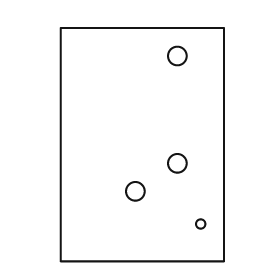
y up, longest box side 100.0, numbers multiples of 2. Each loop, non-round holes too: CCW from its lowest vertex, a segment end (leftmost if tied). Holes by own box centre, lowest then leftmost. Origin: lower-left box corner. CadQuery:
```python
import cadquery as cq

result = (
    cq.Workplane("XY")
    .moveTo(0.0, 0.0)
    .lineTo(70.0, 0.0)
    .lineTo(70.0, 100.0)
    .lineTo(0.0, 100.0)
    .close()
    .moveTo(60.0, 16.0)
    .circle(2.0)
    .moveTo(32.0, 30.0)
    .circle(4.0)
    .moveTo(50.0, 42.0)
    .circle(4.0)
    .moveTo(50.0, 88.0)
    .circle(4.0)
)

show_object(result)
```